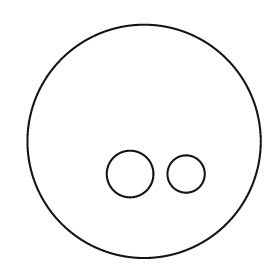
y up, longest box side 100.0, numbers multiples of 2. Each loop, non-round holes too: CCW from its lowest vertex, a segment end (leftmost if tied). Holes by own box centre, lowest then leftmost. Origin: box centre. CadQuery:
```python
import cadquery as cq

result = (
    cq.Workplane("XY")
    .moveTo(0.0, 0.0)
    .circle(50.0)
    .moveTo(-6.0, -14.0)
    .circle(10.0)
    .moveTo(18.0, -14.0)
    .circle(8.0)
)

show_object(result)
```